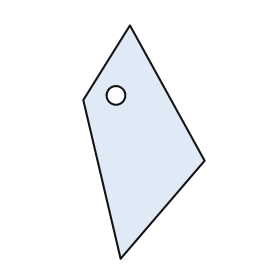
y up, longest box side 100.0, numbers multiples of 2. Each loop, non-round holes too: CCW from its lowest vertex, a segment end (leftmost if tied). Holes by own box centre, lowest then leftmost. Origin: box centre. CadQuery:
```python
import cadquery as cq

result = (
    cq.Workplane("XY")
    .moveTo(-10.0, -50.0)
    .lineTo(26.0, -8.0)
    .lineTo(-6.0, 50.0)
    .lineTo(-26.0, 18.0)
    .close()
    .moveTo(-12.0, 20.0)
    .circle(4.0)
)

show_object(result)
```